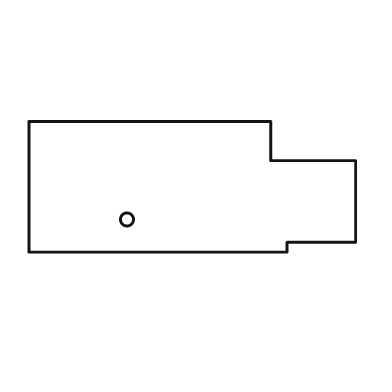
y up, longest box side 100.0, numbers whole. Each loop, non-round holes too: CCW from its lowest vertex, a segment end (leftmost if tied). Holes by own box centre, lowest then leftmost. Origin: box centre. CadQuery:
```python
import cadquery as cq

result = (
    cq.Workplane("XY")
    .moveTo(-50.0, -20.0)
    .lineTo(29.0, -20.0)
    .lineTo(29.0, -17.0)
    .lineTo(50.0, -17.0)
    .lineTo(50.0, 8.0)
    .lineTo(24.0, 8.0)
    .lineTo(24.0, 20.0)
    .lineTo(-50.0, 20.0)
    .close()
    .moveTo(-20.0, -10.0)
    .circle(2.0)
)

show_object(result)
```